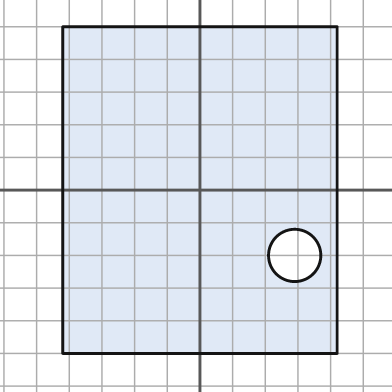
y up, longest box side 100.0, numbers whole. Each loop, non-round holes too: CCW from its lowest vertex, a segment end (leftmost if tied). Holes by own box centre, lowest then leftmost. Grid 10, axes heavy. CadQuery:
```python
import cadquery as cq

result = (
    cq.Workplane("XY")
    .moveTo(-42.0, -50.0)
    .lineTo(42.0, -50.0)
    .lineTo(42.0, 50.0)
    .lineTo(-42.0, 50.0)
    .close()
    .moveTo(29.0, -20.0)
    .circle(8.0)
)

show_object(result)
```